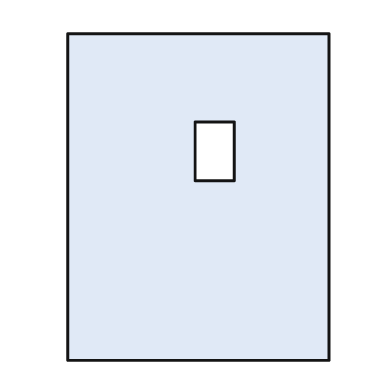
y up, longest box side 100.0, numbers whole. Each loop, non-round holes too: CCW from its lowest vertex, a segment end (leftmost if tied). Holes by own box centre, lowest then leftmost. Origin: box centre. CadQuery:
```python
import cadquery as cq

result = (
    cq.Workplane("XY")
    .moveTo(-40.0, -50.0)
    .lineTo(40.0, -50.0)
    .lineTo(40.0, 50.0)
    .lineTo(-40.0, 50.0)
    .close()
    .moveTo(-1.0, 5.0)
    .lineTo(11.0, 5.0)
    .lineTo(11.0, 23.0)
    .lineTo(-1.0, 23.0)
    .close()
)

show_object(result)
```